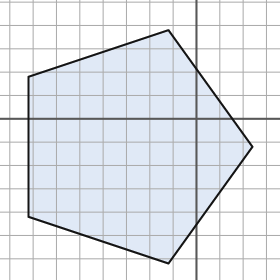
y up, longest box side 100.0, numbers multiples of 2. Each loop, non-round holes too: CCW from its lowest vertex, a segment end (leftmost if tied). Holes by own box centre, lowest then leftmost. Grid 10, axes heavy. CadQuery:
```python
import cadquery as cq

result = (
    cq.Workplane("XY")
    .moveTo(-12.0, -62.0)
    .lineTo(24.0, -12.0)
    .lineTo(-12.0, 38.0)
    .lineTo(-72.0, 18.0)
    .lineTo(-72.0, -42.0)
    .close()
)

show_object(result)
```